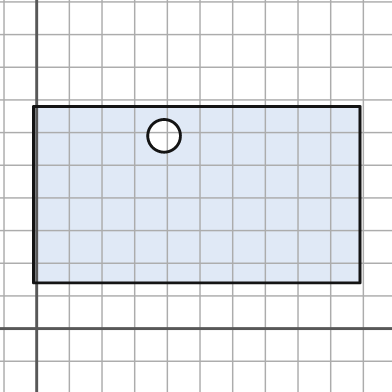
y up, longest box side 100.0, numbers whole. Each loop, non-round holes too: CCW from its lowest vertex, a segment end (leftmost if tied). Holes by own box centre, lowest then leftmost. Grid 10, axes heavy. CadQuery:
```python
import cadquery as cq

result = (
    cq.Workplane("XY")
    .moveTo(-1.0, 14.0)
    .lineTo(99.0, 14.0)
    .lineTo(99.0, 68.0)
    .lineTo(-1.0, 68.0)
    .close()
    .moveTo(39.0, 59.0)
    .circle(5.0)
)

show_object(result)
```